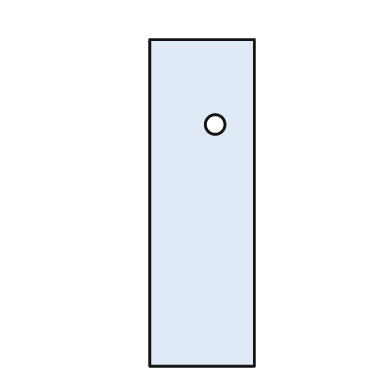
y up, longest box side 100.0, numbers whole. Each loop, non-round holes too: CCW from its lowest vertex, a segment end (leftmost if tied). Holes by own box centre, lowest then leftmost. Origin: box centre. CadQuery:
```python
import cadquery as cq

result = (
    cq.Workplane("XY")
    .moveTo(-16.0, -50.0)
    .lineTo(16.0, -50.0)
    .lineTo(16.0, 50.0)
    .lineTo(-16.0, 50.0)
    .close()
    .moveTo(4.0, 24.0)
    .circle(3.0)
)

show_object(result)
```